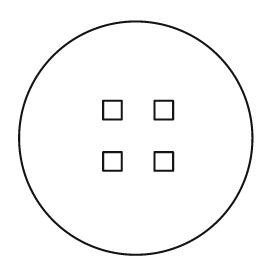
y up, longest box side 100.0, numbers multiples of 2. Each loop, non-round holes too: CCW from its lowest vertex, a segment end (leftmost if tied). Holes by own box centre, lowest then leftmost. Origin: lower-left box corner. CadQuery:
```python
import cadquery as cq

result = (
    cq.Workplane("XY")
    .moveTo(50.0, 50.0)
    .circle(50.0)
    .moveTo(36.0, 36.0)
    .lineTo(44.0, 36.0)
    .lineTo(44.0, 44.0)
    .lineTo(36.0, 44.0)
    .close()
    .moveTo(58.0, 36.0)
    .lineTo(66.0, 36.0)
    .lineTo(66.0, 44.0)
    .lineTo(58.0, 44.0)
    .close()
    .moveTo(36.0, 58.0)
    .lineTo(44.0, 58.0)
    .lineTo(44.0, 66.0)
    .lineTo(36.0, 66.0)
    .close()
    .moveTo(58.0, 58.0)
    .lineTo(66.0, 58.0)
    .lineTo(66.0, 66.0)
    .lineTo(58.0, 66.0)
    .close()
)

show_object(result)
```